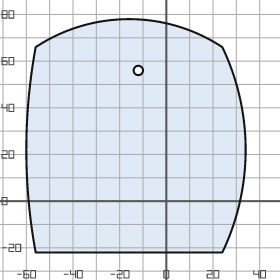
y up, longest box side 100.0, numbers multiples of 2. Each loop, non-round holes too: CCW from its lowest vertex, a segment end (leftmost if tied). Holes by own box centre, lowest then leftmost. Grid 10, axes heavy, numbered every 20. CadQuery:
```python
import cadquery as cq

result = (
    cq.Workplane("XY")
    .moveTo(-56.0, -22.0)
    .lineTo(24.0, -22.0)
    .threePointArc((34.0, 22.0), (24.0, 66.0))
    .threePointArc((-16.0, 78.0), (-56.0, 66.0))
    .threePointArc((-60.0, 22.0), (-56.0, -22.0))
    .close()
    .moveTo(-12.0, 56.0)
    .circle(2.0)
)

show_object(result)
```